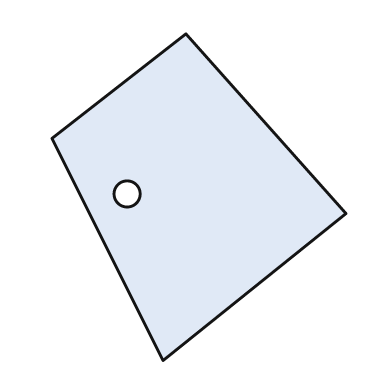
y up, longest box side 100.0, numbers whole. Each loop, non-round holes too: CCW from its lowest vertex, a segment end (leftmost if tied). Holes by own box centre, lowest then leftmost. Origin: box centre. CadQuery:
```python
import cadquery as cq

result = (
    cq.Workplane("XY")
    .moveTo(-11.0, -50.0)
    .lineTo(45.0, -5.0)
    .lineTo(-4.0, 50.0)
    .lineTo(-45.0, 18.0)
    .close()
    .moveTo(-22.0, 1.0)
    .circle(4.0)
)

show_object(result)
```